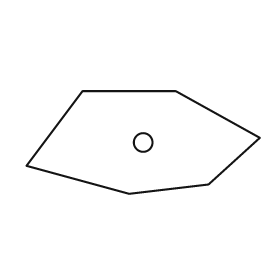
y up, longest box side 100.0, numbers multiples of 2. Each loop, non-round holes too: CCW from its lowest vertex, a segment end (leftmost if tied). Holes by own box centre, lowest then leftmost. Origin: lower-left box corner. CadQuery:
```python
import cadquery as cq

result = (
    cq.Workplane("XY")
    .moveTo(44.0, 0.0)
    .lineTo(78.0, 4.0)
    .lineTo(100.0, 24.0)
    .lineTo(64.0, 44.0)
    .lineTo(24.0, 44.0)
    .lineTo(0.0, 12.0)
    .close()
    .moveTo(50.0, 22.0)
    .circle(4.0)
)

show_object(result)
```